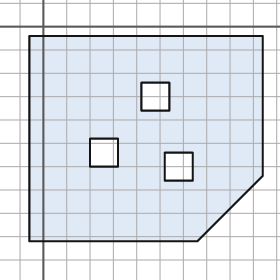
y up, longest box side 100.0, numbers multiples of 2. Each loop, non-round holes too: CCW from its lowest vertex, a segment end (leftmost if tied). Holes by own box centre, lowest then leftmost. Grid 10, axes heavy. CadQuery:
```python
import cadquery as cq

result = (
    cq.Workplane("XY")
    .moveTo(-6.0, -92.0)
    .lineTo(66.0, -92.0)
    .lineTo(94.0, -64.0)
    .lineTo(94.0, -4.0)
    .lineTo(-6.0, -4.0)
    .close()
    .moveTo(52.0, -66.0)
    .lineTo(64.0, -66.0)
    .lineTo(64.0, -54.0)
    .lineTo(52.0, -54.0)
    .close()
    .moveTo(20.0, -60.0)
    .lineTo(32.0, -60.0)
    .lineTo(32.0, -48.0)
    .lineTo(20.0, -48.0)
    .close()
    .moveTo(42.0, -36.0)
    .lineTo(54.0, -36.0)
    .lineTo(54.0, -24.0)
    .lineTo(42.0, -24.0)
    .close()
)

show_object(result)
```